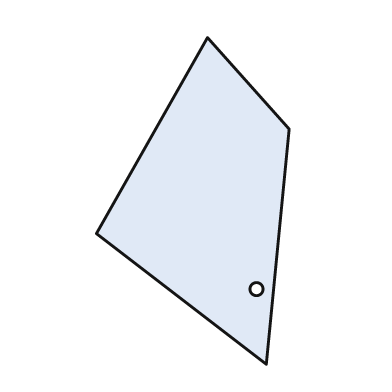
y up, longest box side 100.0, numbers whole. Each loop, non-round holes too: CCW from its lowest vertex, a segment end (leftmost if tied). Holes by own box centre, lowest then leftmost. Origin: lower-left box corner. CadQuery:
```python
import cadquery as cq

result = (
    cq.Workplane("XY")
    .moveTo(52.0, 0.0)
    .lineTo(59.0, 72.0)
    .lineTo(34.0, 100.0)
    .lineTo(0.0, 40.0)
    .close()
    .moveTo(49.0, 23.0)
    .circle(2.0)
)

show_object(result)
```